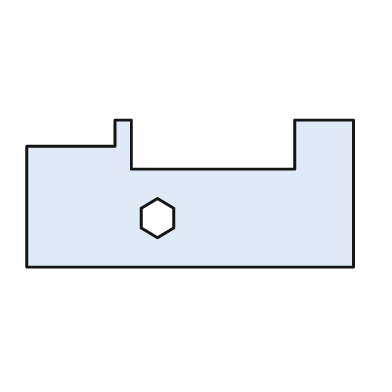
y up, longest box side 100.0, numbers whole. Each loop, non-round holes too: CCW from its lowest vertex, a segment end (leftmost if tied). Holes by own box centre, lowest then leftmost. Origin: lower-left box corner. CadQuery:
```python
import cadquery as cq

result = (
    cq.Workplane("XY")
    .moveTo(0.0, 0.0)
    .lineTo(100.0, 0.0)
    .lineTo(100.0, 45.0)
    .lineTo(82.0, 45.0)
    .lineTo(82.0, 30.0)
    .lineTo(32.0, 30.0)
    .lineTo(32.0, 45.0)
    .lineTo(27.0, 45.0)
    .lineTo(27.0, 37.0)
    .lineTo(0.0, 37.0)
    .close()
    .moveTo(40.0, 9.0)
    .lineTo(45.0, 12.0)
    .lineTo(45.0, 18.0)
    .lineTo(40.0, 21.0)
    .lineTo(35.0, 18.0)
    .lineTo(35.0, 12.0)
    .close()
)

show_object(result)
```